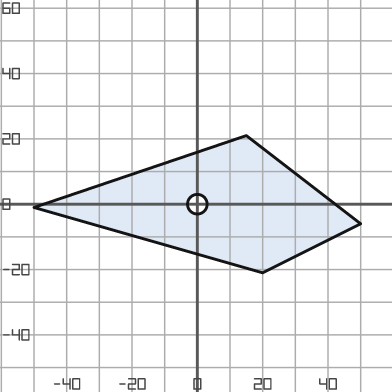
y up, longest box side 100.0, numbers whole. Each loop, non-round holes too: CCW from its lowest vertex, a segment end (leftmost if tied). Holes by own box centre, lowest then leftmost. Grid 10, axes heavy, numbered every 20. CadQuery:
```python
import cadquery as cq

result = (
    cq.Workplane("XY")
    .moveTo(20.0, -21.0)
    .lineTo(50.0, -6.0)
    .lineTo(15.0, 21.0)
    .lineTo(-50.0, -1.0)
    .close()
    .moveTo(0.0, 0.0)
    .circle(3.0)
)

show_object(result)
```